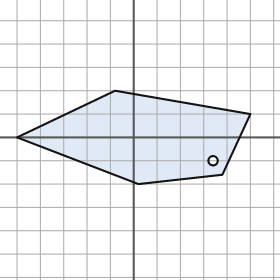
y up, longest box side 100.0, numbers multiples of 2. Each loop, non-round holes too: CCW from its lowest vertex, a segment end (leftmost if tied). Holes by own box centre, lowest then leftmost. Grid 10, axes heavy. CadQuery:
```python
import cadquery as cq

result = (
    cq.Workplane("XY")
    .moveTo(2.0, -20.0)
    .lineTo(38.0, -16.0)
    .lineTo(50.0, 10.0)
    .lineTo(-8.0, 20.0)
    .lineTo(-50.0, 0.0)
    .close()
    .moveTo(34.0, -10.0)
    .circle(2.0)
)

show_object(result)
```